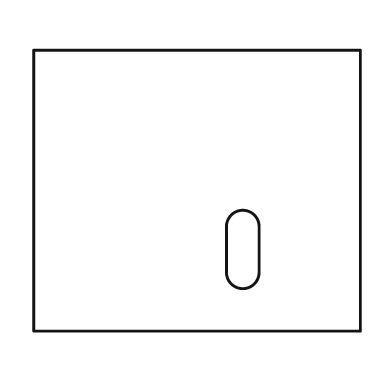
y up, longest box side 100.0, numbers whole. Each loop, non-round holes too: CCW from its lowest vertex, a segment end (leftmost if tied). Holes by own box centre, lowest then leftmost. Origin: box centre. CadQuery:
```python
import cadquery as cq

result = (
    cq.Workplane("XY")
    .moveTo(-50.0, -43.0)
    .lineTo(50.0, -43.0)
    .lineTo(50.0, 43.0)
    .lineTo(-50.0, 43.0)
    .close()
    .moveTo(9.0, -25.0)
    .threePointArc((14.0, -30.0), (19.0, -25.0))
    .lineTo(19.0, -11.0)
    .threePointArc((14.0, -6.0), (9.0, -11.0))
    .close()
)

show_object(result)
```